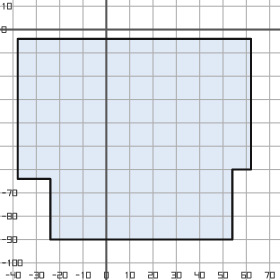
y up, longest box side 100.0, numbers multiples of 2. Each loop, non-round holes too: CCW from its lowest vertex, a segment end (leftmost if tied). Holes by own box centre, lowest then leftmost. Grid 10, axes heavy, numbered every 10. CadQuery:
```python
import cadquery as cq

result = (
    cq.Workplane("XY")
    .moveTo(-24.0, -90.0)
    .lineTo(54.0, -90.0)
    .lineTo(54.0, -60.0)
    .lineTo(62.0, -60.0)
    .lineTo(62.0, -4.0)
    .lineTo(-38.0, -4.0)
    .lineTo(-38.0, -64.0)
    .lineTo(-24.0, -64.0)
    .close()
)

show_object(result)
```